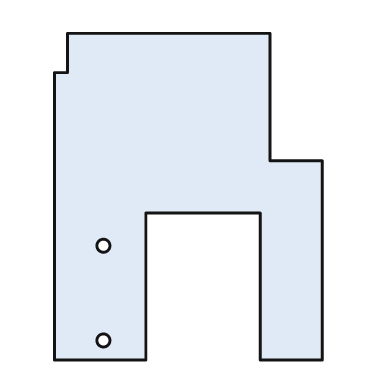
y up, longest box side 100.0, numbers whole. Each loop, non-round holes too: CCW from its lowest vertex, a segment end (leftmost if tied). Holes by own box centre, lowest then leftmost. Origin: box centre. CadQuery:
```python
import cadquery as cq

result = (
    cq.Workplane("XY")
    .moveTo(-41.0, -50.0)
    .lineTo(-13.0, -50.0)
    .lineTo(-13.0, -5.0)
    .lineTo(22.0, -5.0)
    .lineTo(22.0, -50.0)
    .lineTo(41.0, -50.0)
    .lineTo(41.0, 11.0)
    .lineTo(25.0, 11.0)
    .lineTo(25.0, 50.0)
    .lineTo(-37.0, 50.0)
    .lineTo(-37.0, 38.0)
    .lineTo(-41.0, 38.0)
    .close()
    .moveTo(-26.0, -44.0)
    .circle(2.0)
    .moveTo(-26.0, -15.0)
    .circle(2.0)
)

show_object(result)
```